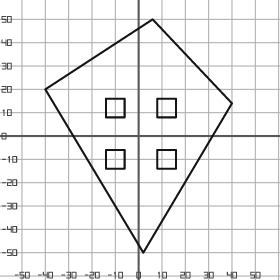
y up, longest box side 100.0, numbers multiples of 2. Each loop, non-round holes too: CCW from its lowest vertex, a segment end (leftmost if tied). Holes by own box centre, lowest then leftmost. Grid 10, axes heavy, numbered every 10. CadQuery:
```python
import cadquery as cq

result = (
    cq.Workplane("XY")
    .moveTo(2.0, -50.0)
    .lineTo(40.0, 14.0)
    .lineTo(6.0, 50.0)
    .lineTo(-40.0, 20.0)
    .close()
    .moveTo(-14.0, -14.0)
    .lineTo(-6.0, -14.0)
    .lineTo(-6.0, -6.0)
    .lineTo(-14.0, -6.0)
    .close()
    .moveTo(8.0, -14.0)
    .lineTo(16.0, -14.0)
    .lineTo(16.0, -6.0)
    .lineTo(8.0, -6.0)
    .close()
    .moveTo(-14.0, 8.0)
    .lineTo(-6.0, 8.0)
    .lineTo(-6.0, 16.0)
    .lineTo(-14.0, 16.0)
    .close()
    .moveTo(8.0, 8.0)
    .lineTo(16.0, 8.0)
    .lineTo(16.0, 16.0)
    .lineTo(8.0, 16.0)
    .close()
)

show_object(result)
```